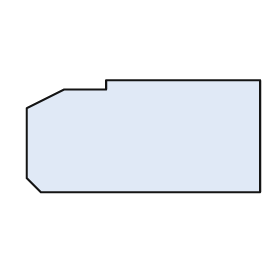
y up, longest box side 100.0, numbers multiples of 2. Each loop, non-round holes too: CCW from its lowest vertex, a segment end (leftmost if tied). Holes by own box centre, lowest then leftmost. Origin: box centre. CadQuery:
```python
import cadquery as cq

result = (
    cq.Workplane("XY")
    .moveTo(-44.0, -24.0)
    .lineTo(50.0, -24.0)
    .lineTo(50.0, 24.0)
    .lineTo(-16.0, 24.0)
    .lineTo(-16.0, 20.0)
    .lineTo(-34.0, 20.0)
    .lineTo(-50.0, 12.0)
    .lineTo(-50.0, -18.0)
    .close()
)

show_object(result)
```